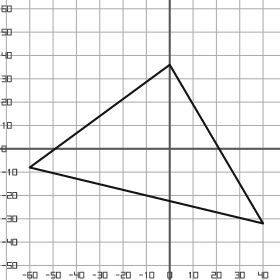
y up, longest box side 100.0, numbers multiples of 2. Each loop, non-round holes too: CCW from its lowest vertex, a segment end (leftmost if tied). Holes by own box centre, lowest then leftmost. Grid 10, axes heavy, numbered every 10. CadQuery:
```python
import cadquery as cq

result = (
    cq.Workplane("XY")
    .moveTo(40.0, -32.0)
    .lineTo(0.0, 36.0)
    .lineTo(-60.0, -8.0)
    .close()
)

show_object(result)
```